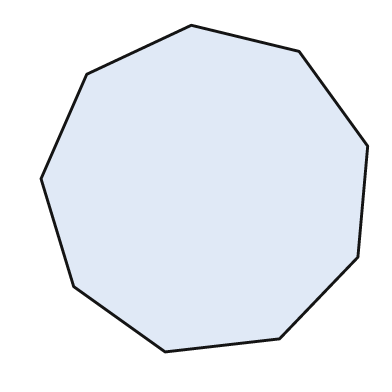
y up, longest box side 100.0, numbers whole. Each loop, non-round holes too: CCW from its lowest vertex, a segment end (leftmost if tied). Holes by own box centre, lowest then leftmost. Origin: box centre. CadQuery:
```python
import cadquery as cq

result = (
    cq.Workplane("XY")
    .moveTo(-12.0, -50.0)
    .lineTo(23.0, -46.0)
    .lineTo(47.0, -21.0)
    .lineTo(50.0, 13.0)
    .lineTo(29.0, 42.0)
    .lineTo(-4.0, 50.0)
    .lineTo(-36.0, 35.0)
    .lineTo(-50.0, 3.0)
    .lineTo(-40.0, -30.0)
    .close()
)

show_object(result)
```